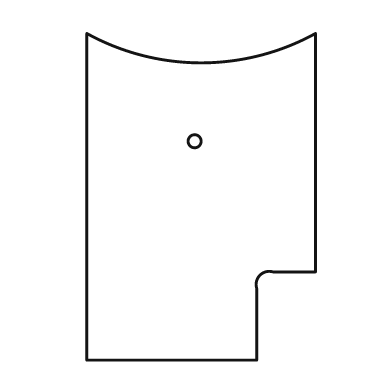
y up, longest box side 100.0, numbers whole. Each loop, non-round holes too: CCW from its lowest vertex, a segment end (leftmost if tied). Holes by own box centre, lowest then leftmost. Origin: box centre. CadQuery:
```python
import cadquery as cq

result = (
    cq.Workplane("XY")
    .moveTo(-35.0, -50.0)
    .lineTo(17.0, -50.0)
    .lineTo(17.0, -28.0)
    .threePointArc((18.0, -24.0), (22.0, -23.0))
    .lineTo(35.0, -23.0)
    .lineTo(35.0, 50.0)
    .threePointArc((0.0, 41.0), (-35.0, 50.0))
    .close()
    .moveTo(-2.0, 17.0)
    .circle(2.0)
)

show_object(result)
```